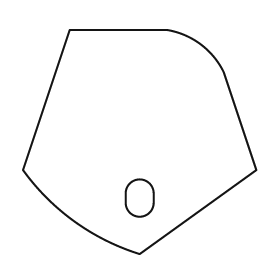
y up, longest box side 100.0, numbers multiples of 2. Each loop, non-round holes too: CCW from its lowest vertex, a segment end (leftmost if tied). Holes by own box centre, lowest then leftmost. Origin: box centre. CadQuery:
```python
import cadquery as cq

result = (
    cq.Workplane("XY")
    .moveTo(0.0, -48.0)
    .lineTo(50.0, -12.0)
    .lineTo(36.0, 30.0)
    .threePointArc((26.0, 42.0), (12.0, 48.0))
    .lineTo(-30.0, 48.0)
    .lineTo(-50.0, -12.0)
    .threePointArc((-28.0, -34.0), (0.0, -48.0))
    .close()
    .moveTo(-6.0, -26.0)
    .threePointArc((0.0, -32.0), (6.0, -26.0))
    .lineTo(6.0, -22.0)
    .threePointArc((0.0, -16.0), (-6.0, -22.0))
    .close()
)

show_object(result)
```